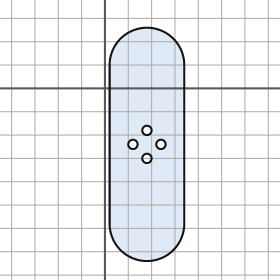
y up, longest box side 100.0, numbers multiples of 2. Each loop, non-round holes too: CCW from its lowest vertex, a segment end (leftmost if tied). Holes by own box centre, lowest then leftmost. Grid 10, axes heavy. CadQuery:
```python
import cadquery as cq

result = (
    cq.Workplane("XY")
    .moveTo(2.0, -58.0)
    .threePointArc((18.0, -74.0), (34.0, -58.0))
    .lineTo(34.0, 10.0)
    .threePointArc((18.0, 26.0), (2.0, 10.0))
    .close()
    .moveTo(18.0, -30.0)
    .circle(2.0)
    .moveTo(12.0, -24.0)
    .circle(2.0)
    .moveTo(24.0, -24.0)
    .circle(2.0)
    .moveTo(18.0, -18.0)
    .circle(2.0)
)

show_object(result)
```